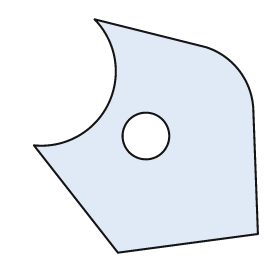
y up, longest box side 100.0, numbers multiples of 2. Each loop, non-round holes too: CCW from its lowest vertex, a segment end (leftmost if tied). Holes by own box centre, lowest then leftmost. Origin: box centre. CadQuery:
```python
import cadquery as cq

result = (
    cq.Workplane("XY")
    .moveTo(-12.0, -50.0)
    .lineTo(48.0, -42.0)
    .lineTo(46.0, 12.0)
    .threePointArc((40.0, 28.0), (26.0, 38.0))
    .lineTo(-22.0, 50.0)
    .threePointArc((-16.0, 14.0), (-48.0, -4.0))
    .close()
    .moveTo(0.0, 0.0)
    .circle(10.0)
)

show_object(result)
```